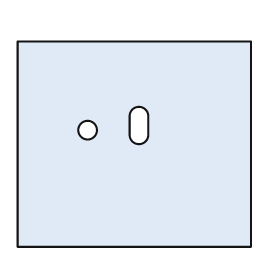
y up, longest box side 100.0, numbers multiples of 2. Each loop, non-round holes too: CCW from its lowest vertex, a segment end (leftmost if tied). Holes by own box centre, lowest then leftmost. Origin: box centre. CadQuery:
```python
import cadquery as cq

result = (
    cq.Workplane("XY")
    .moveTo(-50.0, -44.0)
    .lineTo(50.0, -44.0)
    .lineTo(50.0, 44.0)
    .lineTo(-50.0, 44.0)
    .close()
    .moveTo(-20.0, 6.0)
    .circle(4.0)
    .moveTo(-2.0, 4.0)
    .threePointArc((2.0, 0.0), (6.0, 4.0))
    .lineTo(6.0, 12.0)
    .threePointArc((2.0, 16.0), (-2.0, 12.0))
    .close()
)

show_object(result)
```